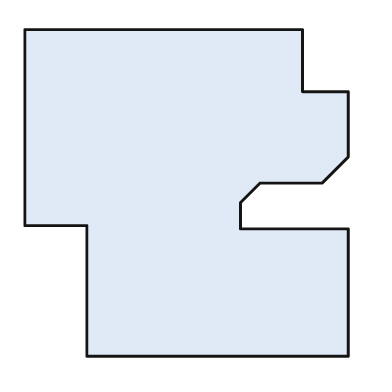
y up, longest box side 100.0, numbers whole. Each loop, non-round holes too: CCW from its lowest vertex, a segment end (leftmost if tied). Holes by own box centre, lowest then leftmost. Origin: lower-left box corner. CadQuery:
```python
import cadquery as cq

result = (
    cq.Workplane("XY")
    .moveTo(19.0, 0.0)
    .lineTo(99.0, 0.0)
    .lineTo(99.0, 39.0)
    .lineTo(66.0, 39.0)
    .lineTo(66.0, 47.0)
    .lineTo(72.0, 53.0)
    .lineTo(91.0, 53.0)
    .lineTo(99.0, 61.0)
    .lineTo(99.0, 81.0)
    .lineTo(85.0, 81.0)
    .lineTo(85.0, 100.0)
    .lineTo(0.0, 100.0)
    .lineTo(0.0, 40.0)
    .lineTo(19.0, 40.0)
    .close()
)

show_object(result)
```